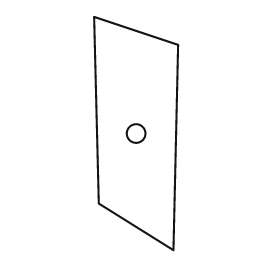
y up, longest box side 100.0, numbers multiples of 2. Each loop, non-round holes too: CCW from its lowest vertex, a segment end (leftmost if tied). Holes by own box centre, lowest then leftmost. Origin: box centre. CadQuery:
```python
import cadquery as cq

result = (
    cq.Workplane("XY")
    .moveTo(16.0, -50.0)
    .lineTo(18.0, 38.0)
    .lineTo(-18.0, 50.0)
    .lineTo(-16.0, -30.0)
    .close()
    .moveTo(0.0, 0.0)
    .circle(4.0)
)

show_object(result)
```